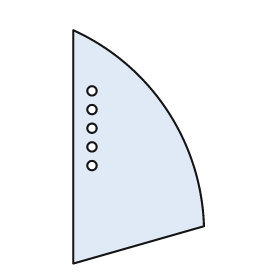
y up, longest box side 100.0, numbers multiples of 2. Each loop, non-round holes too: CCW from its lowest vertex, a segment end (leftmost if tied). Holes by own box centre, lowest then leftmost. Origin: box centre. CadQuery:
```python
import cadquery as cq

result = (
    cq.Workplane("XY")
    .moveTo(-28.0, -50.0)
    .lineTo(28.0, -34.0)
    .threePointArc((12.0, 16.0), (-28.0, 50.0))
    .close()
    .moveTo(-20.0, -8.0)
    .circle(2.0)
    .moveTo(-20.0, 0.0)
    .circle(2.0)
    .moveTo(-20.0, 8.0)
    .circle(2.0)
    .moveTo(-20.0, 16.0)
    .circle(2.0)
    .moveTo(-20.0, 24.0)
    .circle(2.0)
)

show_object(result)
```